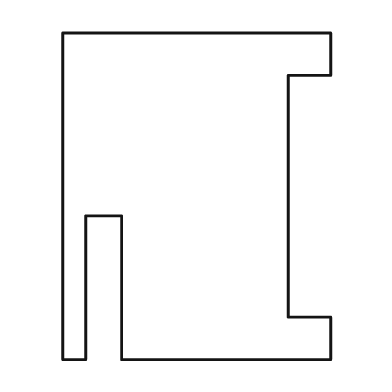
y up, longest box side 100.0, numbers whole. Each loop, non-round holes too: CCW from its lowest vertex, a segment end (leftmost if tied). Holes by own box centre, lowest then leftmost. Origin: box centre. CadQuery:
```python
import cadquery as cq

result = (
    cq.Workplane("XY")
    .moveTo(-41.0, -50.0)
    .lineTo(-34.0, -50.0)
    .lineTo(-34.0, -6.0)
    .lineTo(-23.0, -6.0)
    .lineTo(-23.0, -50.0)
    .lineTo(41.0, -50.0)
    .lineTo(41.0, -37.0)
    .lineTo(28.0, -37.0)
    .lineTo(28.0, 37.0)
    .lineTo(41.0, 37.0)
    .lineTo(41.0, 50.0)
    .lineTo(-41.0, 50.0)
    .close()
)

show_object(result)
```